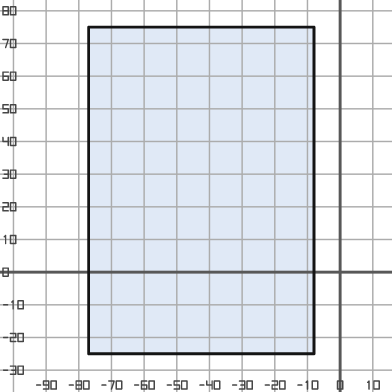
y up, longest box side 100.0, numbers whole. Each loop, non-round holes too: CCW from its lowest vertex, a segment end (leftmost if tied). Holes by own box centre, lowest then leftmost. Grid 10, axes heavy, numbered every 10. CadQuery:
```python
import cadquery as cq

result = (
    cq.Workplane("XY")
    .moveTo(-77.0, -25.0)
    .lineTo(-8.0, -25.0)
    .lineTo(-8.0, 75.0)
    .lineTo(-77.0, 75.0)
    .close()
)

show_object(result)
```